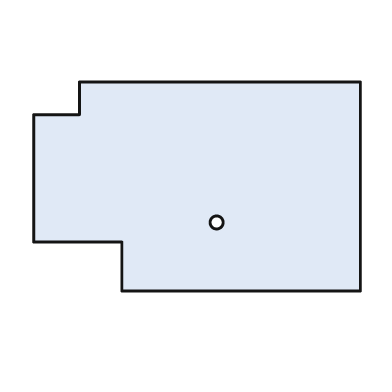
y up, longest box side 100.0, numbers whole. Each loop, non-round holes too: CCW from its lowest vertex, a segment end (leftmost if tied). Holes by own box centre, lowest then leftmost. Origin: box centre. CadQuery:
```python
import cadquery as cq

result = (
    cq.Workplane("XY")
    .moveTo(-23.0, -32.0)
    .lineTo(50.0, -32.0)
    .lineTo(50.0, 32.0)
    .lineTo(-36.0, 32.0)
    .lineTo(-36.0, 22.0)
    .lineTo(-50.0, 22.0)
    .lineTo(-50.0, -17.0)
    .lineTo(-23.0, -17.0)
    .close()
    .moveTo(6.0, -11.0)
    .circle(2.0)
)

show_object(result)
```